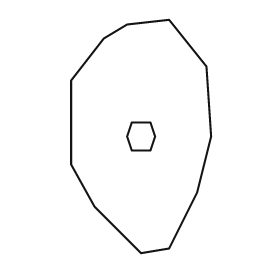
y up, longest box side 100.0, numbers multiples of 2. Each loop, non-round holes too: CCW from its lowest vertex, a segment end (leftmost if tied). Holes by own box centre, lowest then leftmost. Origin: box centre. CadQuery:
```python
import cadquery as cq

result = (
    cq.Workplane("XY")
    .moveTo(0.0, -50.0)
    .lineTo(12.0, -48.0)
    .lineTo(24.0, -24.0)
    .lineTo(30.0, 0.0)
    .lineTo(28.0, 30.0)
    .lineTo(12.0, 50.0)
    .lineTo(-6.0, 48.0)
    .lineTo(-16.0, 42.0)
    .lineTo(-30.0, 24.0)
    .lineTo(-30.0, -12.0)
    .lineTo(-20.0, -30.0)
    .close()
    .moveTo(-4.0, -6.0)
    .lineTo(4.0, -6.0)
    .lineTo(6.0, 0.0)
    .lineTo(4.0, 6.0)
    .lineTo(-4.0, 6.0)
    .lineTo(-6.0, 0.0)
    .close()
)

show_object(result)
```